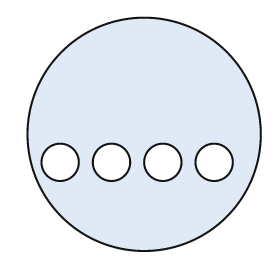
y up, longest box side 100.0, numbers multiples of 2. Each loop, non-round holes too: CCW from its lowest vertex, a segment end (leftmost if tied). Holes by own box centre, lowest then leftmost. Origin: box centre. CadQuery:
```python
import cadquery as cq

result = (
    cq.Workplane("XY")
    .moveTo(0.0, 0.0)
    .circle(50.0)
    .moveTo(-36.0, -12.0)
    .circle(8.0)
    .moveTo(-14.0, -12.0)
    .circle(8.0)
    .moveTo(8.0, -12.0)
    .circle(8.0)
    .moveTo(30.0, -12.0)
    .circle(8.0)
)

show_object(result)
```